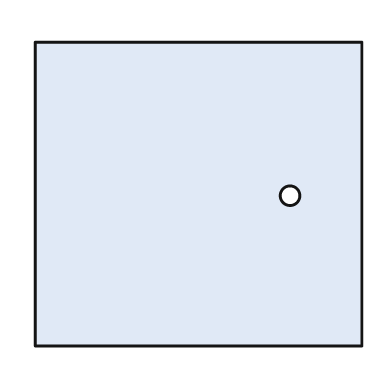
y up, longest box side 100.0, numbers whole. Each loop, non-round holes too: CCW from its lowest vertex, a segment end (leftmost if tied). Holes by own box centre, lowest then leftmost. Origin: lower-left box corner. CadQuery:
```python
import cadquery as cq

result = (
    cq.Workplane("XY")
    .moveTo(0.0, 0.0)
    .lineTo(100.0, 0.0)
    .lineTo(100.0, 93.0)
    .lineTo(0.0, 93.0)
    .close()
    .moveTo(78.0, 46.0)
    .circle(3.0)
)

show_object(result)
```